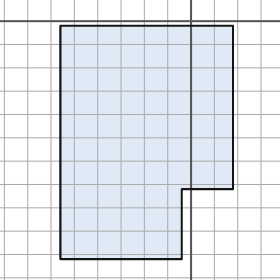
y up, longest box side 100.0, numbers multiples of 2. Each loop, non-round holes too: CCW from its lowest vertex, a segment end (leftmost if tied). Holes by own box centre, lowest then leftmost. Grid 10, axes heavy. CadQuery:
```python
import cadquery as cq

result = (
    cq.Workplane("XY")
    .moveTo(-56.0, -102.0)
    .lineTo(-4.0, -102.0)
    .lineTo(-4.0, -72.0)
    .lineTo(18.0, -72.0)
    .lineTo(18.0, -2.0)
    .lineTo(-56.0, -2.0)
    .close()
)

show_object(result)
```